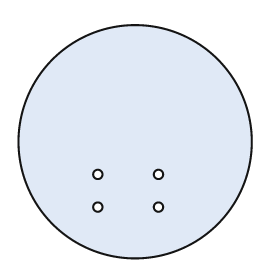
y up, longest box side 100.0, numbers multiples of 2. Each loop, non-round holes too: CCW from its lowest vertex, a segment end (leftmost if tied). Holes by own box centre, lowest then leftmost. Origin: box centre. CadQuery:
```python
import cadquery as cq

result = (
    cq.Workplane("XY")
    .moveTo(0.0, 0.0)
    .circle(50.0)
    .moveTo(-16.0, -28.0)
    .circle(2.0)
    .moveTo(10.0, -28.0)
    .circle(2.0)
    .moveTo(-16.0, -14.0)
    .circle(2.0)
    .moveTo(10.0, -14.0)
    .circle(2.0)
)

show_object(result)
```